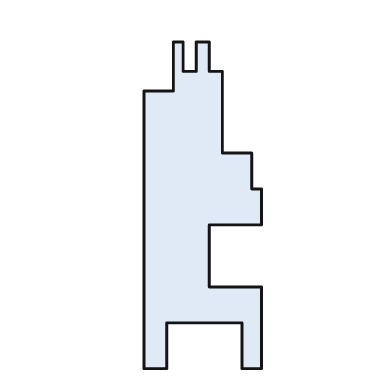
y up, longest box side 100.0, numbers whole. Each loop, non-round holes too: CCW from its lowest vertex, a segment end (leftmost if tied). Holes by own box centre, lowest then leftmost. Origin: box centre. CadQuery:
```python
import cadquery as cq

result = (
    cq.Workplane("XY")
    .moveTo(-18.0, -50.0)
    .lineTo(-11.0, -50.0)
    .lineTo(-11.0, -36.0)
    .lineTo(12.0, -36.0)
    .lineTo(12.0, -50.0)
    .lineTo(18.0, -50.0)
    .lineTo(18.0, -25.0)
    .lineTo(2.0, -25.0)
    .lineTo(2.0, -6.0)
    .lineTo(18.0, -6.0)
    .lineTo(18.0, 5.0)
    .lineTo(15.0, 5.0)
    .lineTo(15.0, 16.0)
    .lineTo(6.0, 16.0)
    .lineTo(6.0, 41.0)
    .lineTo(2.0, 41.0)
    .lineTo(2.0, 50.0)
    .lineTo(-2.0, 50.0)
    .lineTo(-2.0, 41.0)
    .lineTo(-6.0, 41.0)
    .lineTo(-6.0, 50.0)
    .lineTo(-9.0, 50.0)
    .lineTo(-9.0, 35.0)
    .lineTo(-18.0, 35.0)
    .close()
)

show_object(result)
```